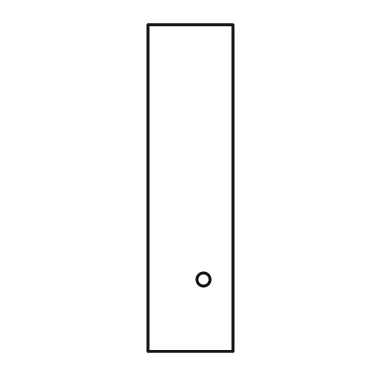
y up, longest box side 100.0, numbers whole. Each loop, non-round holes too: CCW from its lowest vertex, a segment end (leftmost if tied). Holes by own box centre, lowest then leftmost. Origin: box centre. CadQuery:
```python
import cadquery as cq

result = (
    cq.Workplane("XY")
    .moveTo(-13.0, -50.0)
    .lineTo(13.0, -50.0)
    .lineTo(13.0, 50.0)
    .lineTo(-13.0, 50.0)
    .close()
    .moveTo(4.0, -28.0)
    .circle(2.0)
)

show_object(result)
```